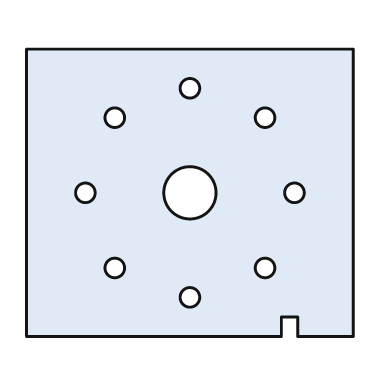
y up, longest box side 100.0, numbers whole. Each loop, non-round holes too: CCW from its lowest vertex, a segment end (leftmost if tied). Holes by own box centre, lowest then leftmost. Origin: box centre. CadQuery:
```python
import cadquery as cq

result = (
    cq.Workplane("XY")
    .moveTo(-50.0, -44.0)
    .lineTo(28.0, -44.0)
    .lineTo(28.0, -38.0)
    .lineTo(33.0, -38.0)
    .lineTo(33.0, -44.0)
    .lineTo(50.0, -44.0)
    .lineTo(50.0, 44.0)
    .lineTo(-50.0, 44.0)
    .close()
    .moveTo(0.0, -32.0)
    .circle(3.0)
    .moveTo(-23.0, -23.0)
    .circle(3.0)
    .moveTo(23.0, -23.0)
    .circle(3.0)
    .moveTo(-32.0, 0.0)
    .circle(3.0)
    .moveTo(0.0, 0.0)
    .circle(8.0)
    .moveTo(32.0, 0.0)
    .circle(3.0)
    .moveTo(-23.0, 23.0)
    .circle(3.0)
    .moveTo(23.0, 23.0)
    .circle(3.0)
    .moveTo(0.0, 32.0)
    .circle(3.0)
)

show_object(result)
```